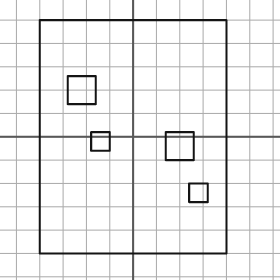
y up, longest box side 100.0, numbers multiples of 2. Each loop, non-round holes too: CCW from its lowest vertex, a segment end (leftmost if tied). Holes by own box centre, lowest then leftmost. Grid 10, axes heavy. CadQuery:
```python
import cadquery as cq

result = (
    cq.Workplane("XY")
    .moveTo(-40.0, -50.0)
    .lineTo(40.0, -50.0)
    .lineTo(40.0, 50.0)
    .lineTo(-40.0, 50.0)
    .close()
    .moveTo(24.0, -28.0)
    .lineTo(32.0, -28.0)
    .lineTo(32.0, -20.0)
    .lineTo(24.0, -20.0)
    .close()
    .moveTo(14.0, -10.0)
    .lineTo(26.0, -10.0)
    .lineTo(26.0, 2.0)
    .lineTo(14.0, 2.0)
    .close()
    .moveTo(-18.0, -6.0)
    .lineTo(-10.0, -6.0)
    .lineTo(-10.0, 2.0)
    .lineTo(-18.0, 2.0)
    .close()
    .moveTo(-28.0, 14.0)
    .lineTo(-16.0, 14.0)
    .lineTo(-16.0, 26.0)
    .lineTo(-28.0, 26.0)
    .close()
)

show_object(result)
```